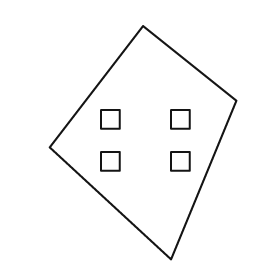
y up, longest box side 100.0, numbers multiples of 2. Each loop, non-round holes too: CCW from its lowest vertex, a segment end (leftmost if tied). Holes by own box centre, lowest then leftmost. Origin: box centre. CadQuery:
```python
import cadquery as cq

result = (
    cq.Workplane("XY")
    .moveTo(12.0, -50.0)
    .lineTo(40.0, 18.0)
    .lineTo(0.0, 50.0)
    .lineTo(-40.0, -2.0)
    .close()
    .moveTo(-18.0, -12.0)
    .lineTo(-10.0, -12.0)
    .lineTo(-10.0, -4.0)
    .lineTo(-18.0, -4.0)
    .close()
    .moveTo(12.0, -12.0)
    .lineTo(20.0, -12.0)
    .lineTo(20.0, -4.0)
    .lineTo(12.0, -4.0)
    .close()
    .moveTo(-18.0, 6.0)
    .lineTo(-10.0, 6.0)
    .lineTo(-10.0, 14.0)
    .lineTo(-18.0, 14.0)
    .close()
    .moveTo(12.0, 6.0)
    .lineTo(20.0, 6.0)
    .lineTo(20.0, 14.0)
    .lineTo(12.0, 14.0)
    .close()
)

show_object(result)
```